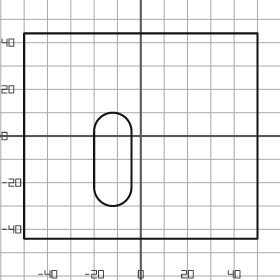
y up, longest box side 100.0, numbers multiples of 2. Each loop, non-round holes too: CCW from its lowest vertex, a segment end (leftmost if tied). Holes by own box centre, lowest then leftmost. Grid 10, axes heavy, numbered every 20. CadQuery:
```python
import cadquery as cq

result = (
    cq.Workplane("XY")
    .moveTo(-50.0, -44.0)
    .lineTo(50.0, -44.0)
    .lineTo(50.0, 44.0)
    .lineTo(-50.0, 44.0)
    .close()
    .moveTo(-20.0, -22.0)
    .threePointArc((-12.0, -30.0), (-4.0, -22.0))
    .lineTo(-4.0, 2.0)
    .threePointArc((-12.0, 10.0), (-20.0, 2.0))
    .close()
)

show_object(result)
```